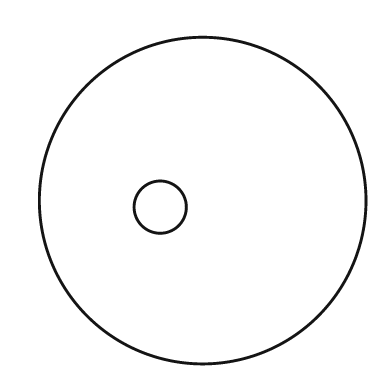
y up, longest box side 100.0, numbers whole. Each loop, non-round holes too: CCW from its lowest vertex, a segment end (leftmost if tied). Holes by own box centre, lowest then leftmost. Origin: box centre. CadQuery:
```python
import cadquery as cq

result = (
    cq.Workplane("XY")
    .moveTo(0.0, 0.0)
    .circle(50.0)
    .moveTo(-13.0, -2.0)
    .circle(8.0)
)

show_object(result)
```